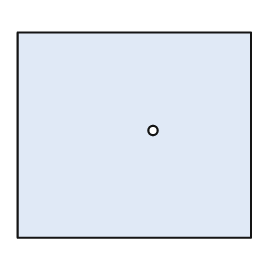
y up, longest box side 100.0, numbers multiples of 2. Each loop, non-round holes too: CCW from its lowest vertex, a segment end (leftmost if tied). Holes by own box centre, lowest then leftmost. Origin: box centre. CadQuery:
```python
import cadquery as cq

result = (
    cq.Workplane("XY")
    .moveTo(-50.0, -44.0)
    .lineTo(50.0, -44.0)
    .lineTo(50.0, 44.0)
    .lineTo(-50.0, 44.0)
    .close()
    .moveTo(8.0, 2.0)
    .circle(2.0)
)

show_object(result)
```